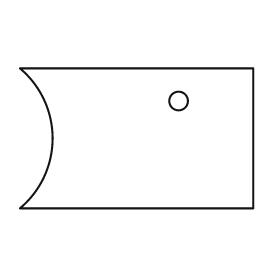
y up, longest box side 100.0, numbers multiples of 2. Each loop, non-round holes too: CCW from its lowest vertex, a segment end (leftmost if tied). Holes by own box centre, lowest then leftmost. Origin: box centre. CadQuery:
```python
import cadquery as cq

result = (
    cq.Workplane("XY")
    .moveTo(-50.0, -30.0)
    .lineTo(50.0, -30.0)
    .lineTo(50.0, 30.0)
    .lineTo(-50.0, 30.0)
    .threePointArc((-36.0, 0.0), (-50.0, -30.0))
    .close()
    .moveTo(18.0, 16.0)
    .circle(4.0)
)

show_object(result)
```